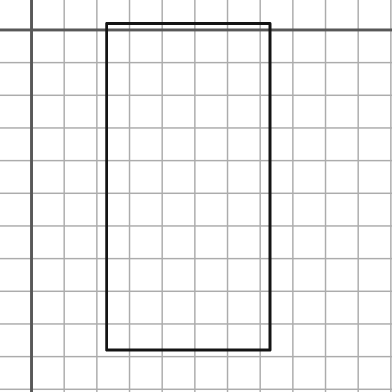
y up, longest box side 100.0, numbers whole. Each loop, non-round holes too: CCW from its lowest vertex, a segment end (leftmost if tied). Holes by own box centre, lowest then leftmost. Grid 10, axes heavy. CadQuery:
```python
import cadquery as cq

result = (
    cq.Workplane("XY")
    .moveTo(23.0, -98.0)
    .lineTo(73.0, -98.0)
    .lineTo(73.0, 2.0)
    .lineTo(23.0, 2.0)
    .close()
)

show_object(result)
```